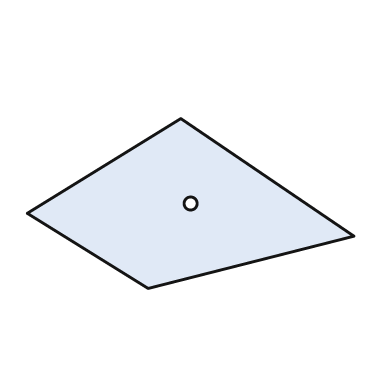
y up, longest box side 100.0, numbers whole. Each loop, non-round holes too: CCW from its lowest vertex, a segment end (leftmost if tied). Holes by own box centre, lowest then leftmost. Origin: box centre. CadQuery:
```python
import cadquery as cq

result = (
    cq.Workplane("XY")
    .moveTo(-13.0, -26.0)
    .lineTo(50.0, -10.0)
    .lineTo(-3.0, 26.0)
    .lineTo(-50.0, -3.0)
    .close()
    .moveTo(0.0, 0.0)
    .circle(2.0)
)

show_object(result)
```